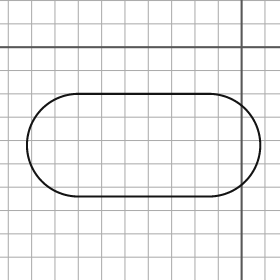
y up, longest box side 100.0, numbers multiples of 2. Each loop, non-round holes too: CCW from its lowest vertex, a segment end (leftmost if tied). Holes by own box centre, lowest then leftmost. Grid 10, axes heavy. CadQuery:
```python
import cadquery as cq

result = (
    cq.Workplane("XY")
    .moveTo(-70.0, -64.0)
    .lineTo(-14.0, -64.0)
    .threePointArc((8.0, -42.0), (-14.0, -20.0))
    .lineTo(-70.0, -20.0)
    .threePointArc((-92.0, -42.0), (-70.0, -64.0))
    .close()
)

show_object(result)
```